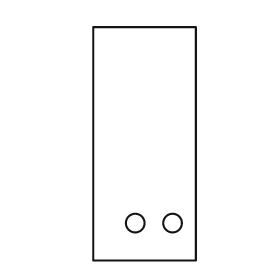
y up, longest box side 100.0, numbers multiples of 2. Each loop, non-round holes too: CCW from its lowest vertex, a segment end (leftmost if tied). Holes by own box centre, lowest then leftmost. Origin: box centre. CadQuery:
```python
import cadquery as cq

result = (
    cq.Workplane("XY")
    .moveTo(-22.0, -50.0)
    .lineTo(22.0, -50.0)
    .lineTo(22.0, 50.0)
    .lineTo(-22.0, 50.0)
    .close()
    .moveTo(-4.0, -34.0)
    .circle(4.0)
    .moveTo(12.0, -34.0)
    .circle(4.0)
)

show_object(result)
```